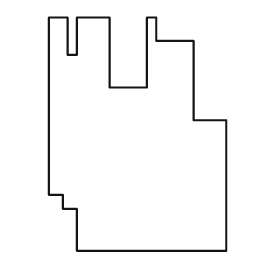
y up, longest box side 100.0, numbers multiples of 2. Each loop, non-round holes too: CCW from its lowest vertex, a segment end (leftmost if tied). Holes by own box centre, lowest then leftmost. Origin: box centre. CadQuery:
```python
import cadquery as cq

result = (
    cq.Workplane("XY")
    .moveTo(-26.0, -50.0)
    .lineTo(38.0, -50.0)
    .lineTo(38.0, 6.0)
    .lineTo(24.0, 6.0)
    .lineTo(24.0, 40.0)
    .lineTo(8.0, 40.0)
    .lineTo(8.0, 50.0)
    .lineTo(4.0, 50.0)
    .lineTo(4.0, 20.0)
    .lineTo(-12.0, 20.0)
    .lineTo(-12.0, 50.0)
    .lineTo(-26.0, 50.0)
    .lineTo(-26.0, 34.0)
    .lineTo(-30.0, 34.0)
    .lineTo(-30.0, 50.0)
    .lineTo(-38.0, 50.0)
    .lineTo(-38.0, -26.0)
    .lineTo(-32.0, -26.0)
    .lineTo(-32.0, -32.0)
    .lineTo(-26.0, -32.0)
    .close()
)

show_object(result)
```